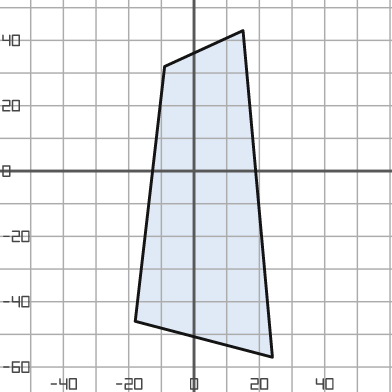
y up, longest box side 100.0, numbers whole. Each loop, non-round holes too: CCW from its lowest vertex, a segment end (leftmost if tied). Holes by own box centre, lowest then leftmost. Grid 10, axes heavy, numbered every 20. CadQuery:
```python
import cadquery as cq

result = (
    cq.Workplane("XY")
    .moveTo(24.0, -57.0)
    .lineTo(15.0, 43.0)
    .lineTo(-9.0, 32.0)
    .lineTo(-18.0, -46.0)
    .close()
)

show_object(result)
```